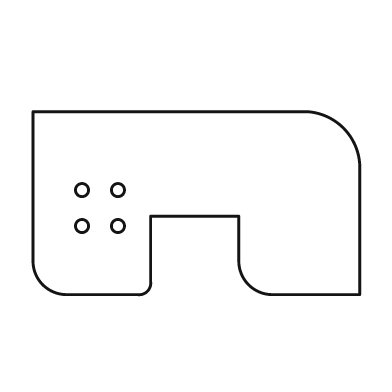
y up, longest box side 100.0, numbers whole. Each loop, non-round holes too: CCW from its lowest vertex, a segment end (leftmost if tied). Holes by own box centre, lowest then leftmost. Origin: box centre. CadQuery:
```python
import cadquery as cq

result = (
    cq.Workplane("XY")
    .moveTo(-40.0, -28.0)
    .lineTo(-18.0, -28.0)
    .threePointArc((-15.0, -27.0), (-14.0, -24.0))
    .lineTo(-14.0, -4.0)
    .lineTo(13.0, -4.0)
    .lineTo(13.0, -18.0)
    .threePointArc((16.0, -25.0), (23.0, -28.0))
    .lineTo(50.0, -28.0)
    .lineTo(50.0, 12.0)
    .threePointArc((45.0, 23.0), (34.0, 28.0))
    .lineTo(-50.0, 28.0)
    .lineTo(-50.0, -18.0)
    .threePointArc((-47.0, -25.0), (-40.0, -28.0))
    .close()
    .moveTo(-35.0, -7.0)
    .circle(2.0)
    .moveTo(-24.0, -7.0)
    .circle(2.0)
    .moveTo(-35.0, 4.0)
    .circle(2.0)
    .moveTo(-24.0, 4.0)
    .circle(2.0)
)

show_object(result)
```